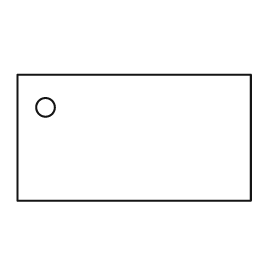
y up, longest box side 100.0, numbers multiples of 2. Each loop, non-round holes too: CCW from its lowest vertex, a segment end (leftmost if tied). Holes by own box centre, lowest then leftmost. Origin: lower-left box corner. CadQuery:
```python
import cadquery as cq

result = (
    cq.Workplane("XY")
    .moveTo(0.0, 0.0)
    .lineTo(100.0, 0.0)
    .lineTo(100.0, 54.0)
    .lineTo(0.0, 54.0)
    .close()
    .moveTo(12.0, 40.0)
    .circle(4.0)
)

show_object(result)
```